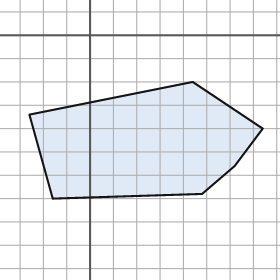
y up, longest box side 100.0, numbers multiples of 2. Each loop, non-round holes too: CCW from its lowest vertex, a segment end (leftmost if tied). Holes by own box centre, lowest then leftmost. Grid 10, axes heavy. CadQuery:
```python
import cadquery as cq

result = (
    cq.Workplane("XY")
    .moveTo(-16.0, -70.0)
    .lineTo(48.0, -68.0)
    .lineTo(62.0, -56.0)
    .lineTo(74.0, -40.0)
    .lineTo(44.0, -20.0)
    .lineTo(-26.0, -34.0)
    .close()
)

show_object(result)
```